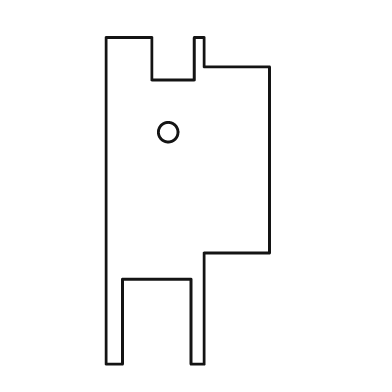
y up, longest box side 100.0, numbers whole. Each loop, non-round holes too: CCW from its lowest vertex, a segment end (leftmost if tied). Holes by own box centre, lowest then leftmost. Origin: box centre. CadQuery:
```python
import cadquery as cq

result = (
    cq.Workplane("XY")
    .moveTo(-25.0, -50.0)
    .lineTo(-20.0, -50.0)
    .lineTo(-20.0, -24.0)
    .lineTo(1.0, -24.0)
    .lineTo(1.0, -50.0)
    .lineTo(5.0, -50.0)
    .lineTo(5.0, -16.0)
    .lineTo(25.0, -16.0)
    .lineTo(25.0, 41.0)
    .lineTo(5.0, 41.0)
    .lineTo(5.0, 50.0)
    .lineTo(2.0, 50.0)
    .lineTo(2.0, 37.0)
    .lineTo(-11.0, 37.0)
    .lineTo(-11.0, 50.0)
    .lineTo(-25.0, 50.0)
    .close()
    .moveTo(-6.0, 21.0)
    .circle(3.0)
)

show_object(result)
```